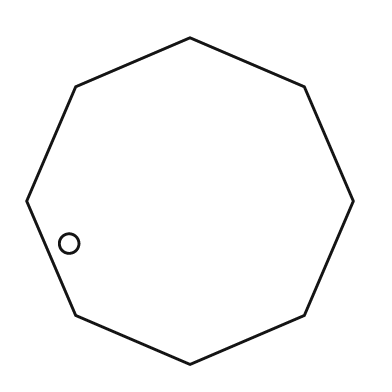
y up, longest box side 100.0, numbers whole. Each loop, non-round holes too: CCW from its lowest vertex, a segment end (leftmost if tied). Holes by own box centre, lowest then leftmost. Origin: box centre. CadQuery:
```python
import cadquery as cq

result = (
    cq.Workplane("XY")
    .moveTo(0.0, -50.0)
    .lineTo(35.0, -35.0)
    .lineTo(50.0, 0.0)
    .lineTo(35.0, 35.0)
    .lineTo(0.0, 50.0)
    .lineTo(-35.0, 35.0)
    .lineTo(-50.0, 0.0)
    .lineTo(-35.0, -35.0)
    .close()
    .moveTo(-37.0, -13.0)
    .circle(3.0)
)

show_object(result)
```